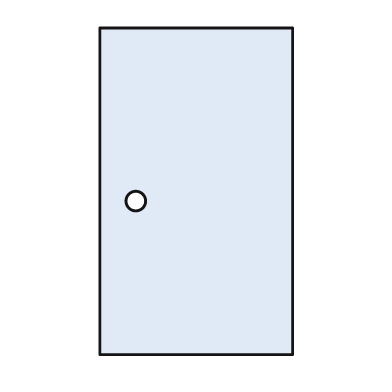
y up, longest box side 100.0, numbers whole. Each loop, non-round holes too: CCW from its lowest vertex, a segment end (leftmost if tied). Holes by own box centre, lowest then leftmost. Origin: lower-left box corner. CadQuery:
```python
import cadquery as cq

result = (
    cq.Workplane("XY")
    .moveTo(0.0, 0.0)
    .lineTo(59.0, 0.0)
    .lineTo(59.0, 100.0)
    .lineTo(0.0, 100.0)
    .close()
    .moveTo(11.0, 47.0)
    .circle(3.0)
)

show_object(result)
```